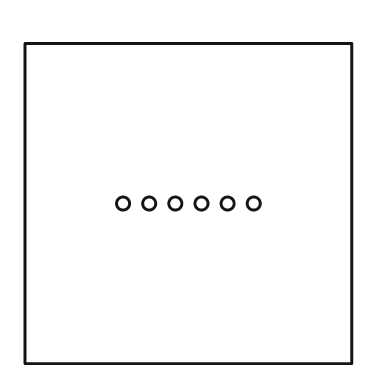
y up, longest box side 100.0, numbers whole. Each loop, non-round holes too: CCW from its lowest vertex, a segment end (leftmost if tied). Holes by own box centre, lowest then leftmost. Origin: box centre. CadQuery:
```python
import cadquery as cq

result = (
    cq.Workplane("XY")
    .moveTo(-50.0, -49.0)
    .lineTo(50.0, -49.0)
    .lineTo(50.0, 49.0)
    .lineTo(-50.0, 49.0)
    .close()
    .moveTo(-20.0, 0.0)
    .circle(2.0)
    .moveTo(-12.0, 0.0)
    .circle(2.0)
    .moveTo(-4.0, 0.0)
    .circle(2.0)
    .moveTo(4.0, 0.0)
    .circle(2.0)
    .moveTo(12.0, 0.0)
    .circle(2.0)
    .moveTo(20.0, 0.0)
    .circle(2.0)
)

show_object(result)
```